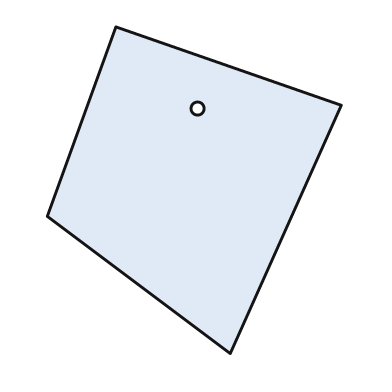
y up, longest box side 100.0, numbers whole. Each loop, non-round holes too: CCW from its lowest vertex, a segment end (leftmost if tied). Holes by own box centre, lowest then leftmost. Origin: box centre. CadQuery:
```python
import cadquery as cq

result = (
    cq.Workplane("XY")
    .moveTo(11.0, -50.0)
    .lineTo(45.0, 26.0)
    .lineTo(-24.0, 50.0)
    .lineTo(-45.0, -8.0)
    .close()
    .moveTo(1.0, 25.0)
    .circle(2.0)
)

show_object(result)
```